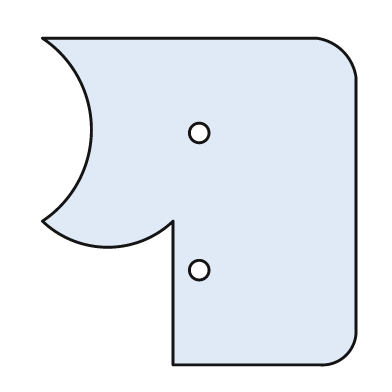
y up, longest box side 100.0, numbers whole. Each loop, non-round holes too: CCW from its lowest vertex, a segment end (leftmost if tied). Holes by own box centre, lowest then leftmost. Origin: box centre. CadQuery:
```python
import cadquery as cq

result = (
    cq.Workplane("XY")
    .moveTo(-8.0, -50.0)
    .lineTo(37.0, -50.0)
    .threePointArc((45.0, -47.0), (48.0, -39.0))
    .lineTo(48.0, 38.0)
    .threePointArc((44.0, 46.0), (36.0, 50.0))
    .lineTo(-48.0, 50.0)
    .threePointArc((-33.0, 22.0), (-48.0, -6.0))
    .threePointArc((-28.0, -14.0), (-8.0, -6.0))
    .close()
    .moveTo(0.0, -21.0)
    .circle(3.0)
    .moveTo(0.0, 21.0)
    .circle(3.0)
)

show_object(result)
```